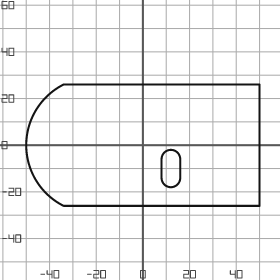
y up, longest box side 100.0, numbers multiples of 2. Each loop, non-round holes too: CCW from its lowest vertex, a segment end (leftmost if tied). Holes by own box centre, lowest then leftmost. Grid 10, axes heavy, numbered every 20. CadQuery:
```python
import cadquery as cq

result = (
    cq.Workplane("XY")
    .moveTo(-34.0, -26.0)
    .lineTo(50.0, -26.0)
    .lineTo(50.0, 26.0)
    .lineTo(-34.0, 26.0)
    .threePointArc((-50.0, 0.0), (-34.0, -26.0))
    .close()
    .moveTo(8.0, -14.0)
    .threePointArc((12.0, -18.0), (16.0, -14.0))
    .lineTo(16.0, -6.0)
    .threePointArc((12.0, -2.0), (8.0, -6.0))
    .close()
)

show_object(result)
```